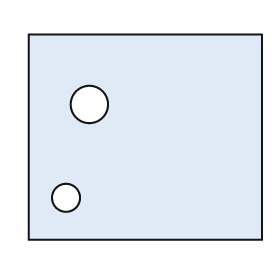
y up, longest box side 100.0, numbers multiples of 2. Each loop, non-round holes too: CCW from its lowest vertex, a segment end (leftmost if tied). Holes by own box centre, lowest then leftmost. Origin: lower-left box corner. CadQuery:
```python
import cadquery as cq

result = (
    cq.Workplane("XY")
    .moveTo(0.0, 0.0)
    .lineTo(100.0, 0.0)
    .lineTo(100.0, 88.0)
    .lineTo(0.0, 88.0)
    .close()
    .moveTo(16.0, 18.0)
    .circle(6.0)
    .moveTo(26.0, 58.0)
    .circle(8.0)
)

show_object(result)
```